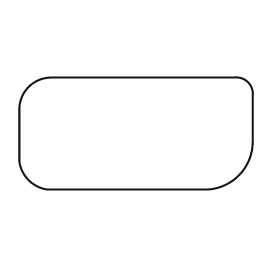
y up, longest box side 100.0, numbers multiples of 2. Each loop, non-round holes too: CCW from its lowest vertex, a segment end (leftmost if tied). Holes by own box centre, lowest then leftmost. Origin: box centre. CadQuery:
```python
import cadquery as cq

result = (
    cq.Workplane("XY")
    .moveTo(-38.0, -24.0)
    .lineTo(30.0, -24.0)
    .threePointArc((44.0, -18.0), (50.0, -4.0))
    .lineTo(50.0, 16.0)
    .threePointArc((48.0, 22.0), (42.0, 24.0))
    .lineTo(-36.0, 24.0)
    .threePointArc((-46.0, 20.0), (-50.0, 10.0))
    .lineTo(-50.0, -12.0)
    .threePointArc((-46.0, -20.0), (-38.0, -24.0))
    .close()
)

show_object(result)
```